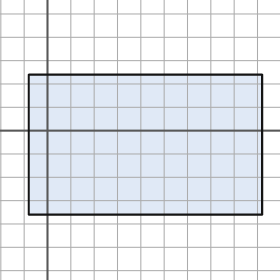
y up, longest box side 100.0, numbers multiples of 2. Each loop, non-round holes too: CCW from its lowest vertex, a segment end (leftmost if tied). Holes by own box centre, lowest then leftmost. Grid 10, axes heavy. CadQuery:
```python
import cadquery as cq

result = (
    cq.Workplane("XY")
    .moveTo(-8.0, -36.0)
    .lineTo(92.0, -36.0)
    .lineTo(92.0, 24.0)
    .lineTo(-8.0, 24.0)
    .close()
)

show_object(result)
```